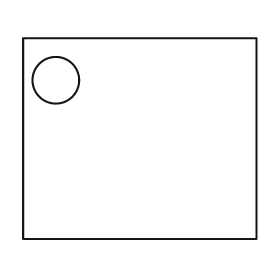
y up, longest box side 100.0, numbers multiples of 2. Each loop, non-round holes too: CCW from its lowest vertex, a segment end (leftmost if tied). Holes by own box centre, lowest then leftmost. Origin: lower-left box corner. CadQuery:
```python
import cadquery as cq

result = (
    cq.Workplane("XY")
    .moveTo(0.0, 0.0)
    .lineTo(100.0, 0.0)
    .lineTo(100.0, 86.0)
    .lineTo(0.0, 86.0)
    .close()
    .moveTo(14.0, 68.0)
    .circle(10.0)
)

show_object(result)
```